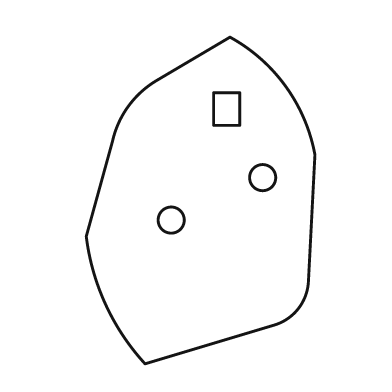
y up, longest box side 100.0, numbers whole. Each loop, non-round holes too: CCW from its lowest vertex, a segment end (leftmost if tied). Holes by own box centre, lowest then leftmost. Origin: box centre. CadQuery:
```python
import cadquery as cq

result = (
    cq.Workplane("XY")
    .moveTo(-17.0, -50.0)
    .lineTo(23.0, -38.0)
    .threePointArc((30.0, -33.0), (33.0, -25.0))
    .lineTo(35.0, 14.0)
    .threePointArc((26.0, 35.0), (9.0, 50.0))
    .lineTo(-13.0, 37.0)
    .threePointArc((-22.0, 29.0), (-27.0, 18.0))
    .lineTo(-35.0, -11.0)
    .threePointArc((-29.0, -32.0), (-17.0, -50.0))
    .close()
    .moveTo(-9.0, -6.0)
    .circle(4.0)
    .moveTo(19.0, 7.0)
    .circle(4.0)
    .moveTo(4.0, 23.0)
    .lineTo(12.0, 23.0)
    .lineTo(12.0, 33.0)
    .lineTo(4.0, 33.0)
    .close()
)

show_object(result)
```